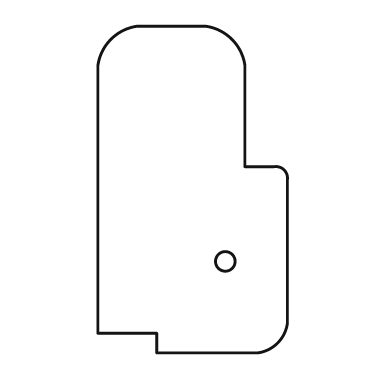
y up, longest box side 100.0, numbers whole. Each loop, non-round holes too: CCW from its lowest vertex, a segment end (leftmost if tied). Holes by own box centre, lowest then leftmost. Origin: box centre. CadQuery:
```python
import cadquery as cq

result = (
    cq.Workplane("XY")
    .moveTo(-11.0, -50.0)
    .lineTo(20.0, -50.0)
    .threePointArc((26.0, -47.0), (29.0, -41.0))
    .lineTo(29.0, 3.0)
    .threePointArc((28.0, 6.0), (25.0, 7.0))
    .lineTo(16.0, 7.0)
    .lineTo(16.0, 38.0)
    .threePointArc((12.0, 46.0), (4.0, 50.0))
    .lineTo(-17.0, 50.0)
    .threePointArc((-25.0, 46.0), (-29.0, 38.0))
    .lineTo(-29.0, -44.0)
    .lineTo(-11.0, -44.0)
    .close()
    .moveTo(10.0, -22.0)
    .circle(3.0)
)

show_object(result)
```